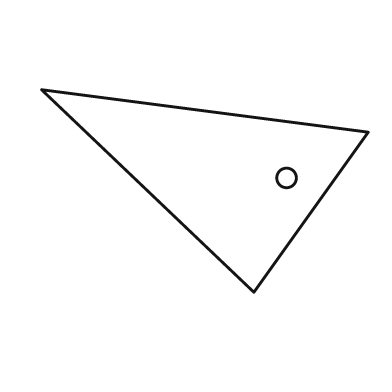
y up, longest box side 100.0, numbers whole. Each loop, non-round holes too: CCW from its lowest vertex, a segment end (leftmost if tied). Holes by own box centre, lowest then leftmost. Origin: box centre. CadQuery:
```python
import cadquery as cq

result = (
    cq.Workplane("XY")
    .moveTo(15.0, -31.0)
    .lineTo(50.0, 18.0)
    .lineTo(-50.0, 31.0)
    .close()
    .moveTo(25.0, 4.0)
    .circle(3.0)
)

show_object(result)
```